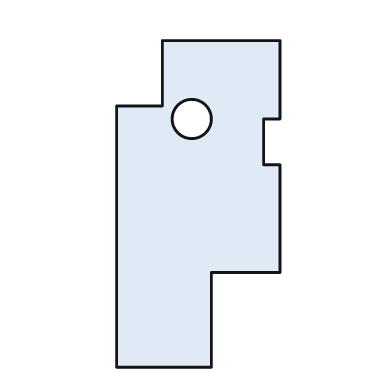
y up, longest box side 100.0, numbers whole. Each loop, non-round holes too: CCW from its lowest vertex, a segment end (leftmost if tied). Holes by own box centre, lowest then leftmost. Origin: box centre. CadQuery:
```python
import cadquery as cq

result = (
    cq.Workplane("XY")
    .moveTo(-25.0, -50.0)
    .lineTo(4.0, -50.0)
    .lineTo(4.0, -21.0)
    .lineTo(25.0, -21.0)
    .lineTo(25.0, 12.0)
    .lineTo(20.0, 12.0)
    .lineTo(20.0, 26.0)
    .lineTo(25.0, 26.0)
    .lineTo(25.0, 50.0)
    .lineTo(-11.0, 50.0)
    .lineTo(-11.0, 30.0)
    .lineTo(-25.0, 30.0)
    .close()
    .moveTo(-2.0, 26.0)
    .circle(6.0)
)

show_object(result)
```